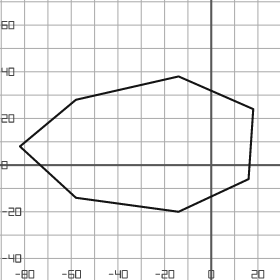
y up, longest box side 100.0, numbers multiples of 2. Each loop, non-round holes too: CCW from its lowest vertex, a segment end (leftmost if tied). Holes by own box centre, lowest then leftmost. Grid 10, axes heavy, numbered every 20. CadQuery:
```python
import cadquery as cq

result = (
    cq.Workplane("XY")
    .moveTo(-14.0, -20.0)
    .lineTo(16.0, -6.0)
    .lineTo(18.0, 24.0)
    .lineTo(-14.0, 38.0)
    .lineTo(-58.0, 28.0)
    .lineTo(-82.0, 8.0)
    .lineTo(-58.0, -14.0)
    .close()
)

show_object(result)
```